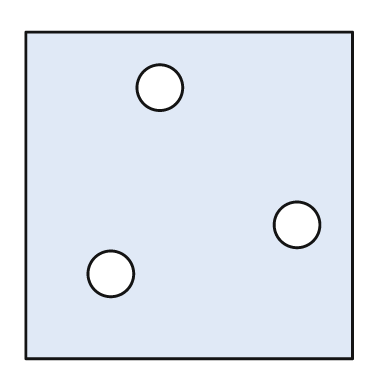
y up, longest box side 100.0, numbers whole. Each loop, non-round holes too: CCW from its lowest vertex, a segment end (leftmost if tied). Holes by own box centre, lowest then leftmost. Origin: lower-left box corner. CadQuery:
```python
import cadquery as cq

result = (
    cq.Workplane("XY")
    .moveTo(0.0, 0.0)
    .lineTo(100.0, 0.0)
    .lineTo(100.0, 100.0)
    .lineTo(0.0, 100.0)
    .close()
    .moveTo(26.0, 26.0)
    .circle(7.0)
    .moveTo(83.0, 41.0)
    .circle(7.0)
    .moveTo(41.0, 83.0)
    .circle(7.0)
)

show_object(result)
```